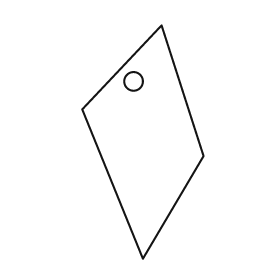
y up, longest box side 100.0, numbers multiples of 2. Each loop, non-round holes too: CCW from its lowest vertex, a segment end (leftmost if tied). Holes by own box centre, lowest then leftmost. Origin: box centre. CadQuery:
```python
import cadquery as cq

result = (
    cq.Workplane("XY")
    .moveTo(0.0, -50.0)
    .lineTo(26.0, -6.0)
    .lineTo(8.0, 50.0)
    .lineTo(-26.0, 14.0)
    .close()
    .moveTo(-4.0, 26.0)
    .circle(4.0)
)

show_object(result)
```